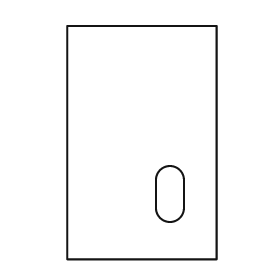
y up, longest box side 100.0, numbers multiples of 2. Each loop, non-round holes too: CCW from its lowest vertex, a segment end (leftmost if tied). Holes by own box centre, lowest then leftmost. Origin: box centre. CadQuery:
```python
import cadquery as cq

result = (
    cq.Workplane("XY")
    .moveTo(-32.0, -50.0)
    .lineTo(32.0, -50.0)
    .lineTo(32.0, 50.0)
    .lineTo(-32.0, 50.0)
    .close()
    .moveTo(6.0, -28.0)
    .threePointArc((12.0, -34.0), (18.0, -28.0))
    .lineTo(18.0, -16.0)
    .threePointArc((12.0, -10.0), (6.0, -16.0))
    .close()
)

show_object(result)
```